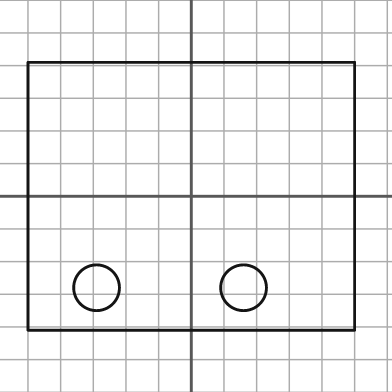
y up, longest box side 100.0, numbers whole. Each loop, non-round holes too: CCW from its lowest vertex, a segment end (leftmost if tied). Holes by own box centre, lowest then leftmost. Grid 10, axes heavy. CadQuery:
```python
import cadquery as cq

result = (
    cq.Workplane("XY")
    .moveTo(-50.0, -41.0)
    .lineTo(50.0, -41.0)
    .lineTo(50.0, 41.0)
    .lineTo(-50.0, 41.0)
    .close()
    .moveTo(-29.0, -28.0)
    .circle(7.0)
    .moveTo(16.0, -28.0)
    .circle(7.0)
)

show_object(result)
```